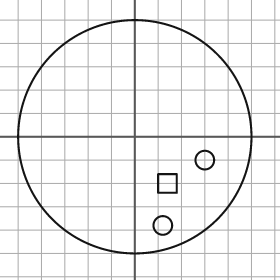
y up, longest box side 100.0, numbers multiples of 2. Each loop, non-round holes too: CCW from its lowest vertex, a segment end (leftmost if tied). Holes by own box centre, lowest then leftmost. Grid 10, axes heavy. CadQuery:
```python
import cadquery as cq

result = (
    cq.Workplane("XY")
    .moveTo(0.0, 0.0)
    .circle(50.0)
    .moveTo(12.0, -38.0)
    .circle(4.0)
    .moveTo(10.0, -24.0)
    .lineTo(18.0, -24.0)
    .lineTo(18.0, -16.0)
    .lineTo(10.0, -16.0)
    .close()
    .moveTo(30.0, -10.0)
    .circle(4.0)
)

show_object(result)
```